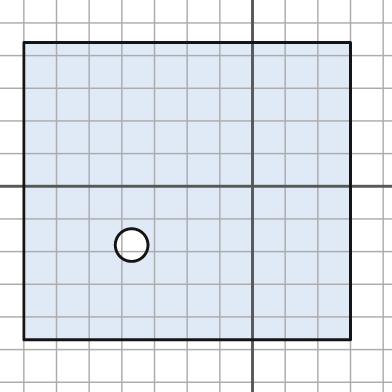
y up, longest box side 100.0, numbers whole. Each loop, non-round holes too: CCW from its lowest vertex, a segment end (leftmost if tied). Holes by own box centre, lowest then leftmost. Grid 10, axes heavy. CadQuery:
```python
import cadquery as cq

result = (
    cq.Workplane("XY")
    .moveTo(-70.0, -47.0)
    .lineTo(30.0, -47.0)
    .lineTo(30.0, 44.0)
    .lineTo(-70.0, 44.0)
    .close()
    .moveTo(-37.0, -18.0)
    .circle(5.0)
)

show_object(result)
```